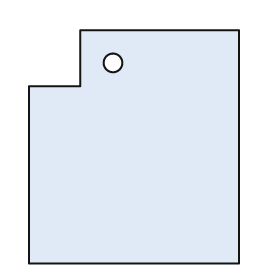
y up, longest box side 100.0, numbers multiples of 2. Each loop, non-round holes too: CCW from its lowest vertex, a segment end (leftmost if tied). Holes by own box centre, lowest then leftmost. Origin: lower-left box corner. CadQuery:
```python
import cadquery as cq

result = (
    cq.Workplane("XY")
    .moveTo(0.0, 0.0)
    .lineTo(90.0, 0.0)
    .lineTo(90.0, 100.0)
    .lineTo(22.0, 100.0)
    .lineTo(22.0, 76.0)
    .lineTo(0.0, 76.0)
    .close()
    .moveTo(36.0, 86.0)
    .circle(4.0)
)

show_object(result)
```